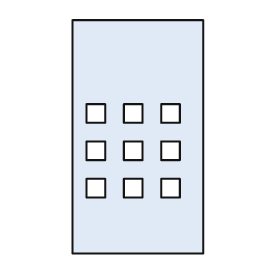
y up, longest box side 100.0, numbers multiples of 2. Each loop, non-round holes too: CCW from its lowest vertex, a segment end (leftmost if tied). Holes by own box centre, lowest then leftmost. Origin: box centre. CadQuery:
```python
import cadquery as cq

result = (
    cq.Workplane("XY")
    .moveTo(-28.0, -50.0)
    .lineTo(28.0, -50.0)
    .lineTo(28.0, 50.0)
    .lineTo(-28.0, 50.0)
    .close()
    .moveTo(-22.0, -26.0)
    .lineTo(-14.0, -26.0)
    .lineTo(-14.0, -18.0)
    .lineTo(-22.0, -18.0)
    .close()
    .moveTo(-6.0, -26.0)
    .lineTo(2.0, -26.0)
    .lineTo(2.0, -18.0)
    .lineTo(-6.0, -18.0)
    .close()
    .moveTo(10.0, -26.0)
    .lineTo(18.0, -26.0)
    .lineTo(18.0, -18.0)
    .lineTo(10.0, -18.0)
    .close()
    .moveTo(-22.0, -10.0)
    .lineTo(-14.0, -10.0)
    .lineTo(-14.0, -2.0)
    .lineTo(-22.0, -2.0)
    .close()
    .moveTo(-6.0, -10.0)
    .lineTo(2.0, -10.0)
    .lineTo(2.0, -2.0)
    .lineTo(-6.0, -2.0)
    .close()
    .moveTo(10.0, -10.0)
    .lineTo(18.0, -10.0)
    .lineTo(18.0, -2.0)
    .lineTo(10.0, -2.0)
    .close()
    .moveTo(-22.0, 6.0)
    .lineTo(-14.0, 6.0)
    .lineTo(-14.0, 14.0)
    .lineTo(-22.0, 14.0)
    .close()
    .moveTo(-6.0, 6.0)
    .lineTo(2.0, 6.0)
    .lineTo(2.0, 14.0)
    .lineTo(-6.0, 14.0)
    .close()
    .moveTo(10.0, 6.0)
    .lineTo(18.0, 6.0)
    .lineTo(18.0, 14.0)
    .lineTo(10.0, 14.0)
    .close()
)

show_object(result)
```